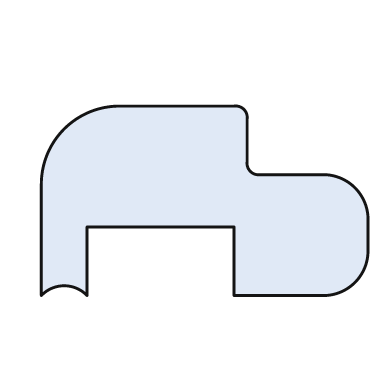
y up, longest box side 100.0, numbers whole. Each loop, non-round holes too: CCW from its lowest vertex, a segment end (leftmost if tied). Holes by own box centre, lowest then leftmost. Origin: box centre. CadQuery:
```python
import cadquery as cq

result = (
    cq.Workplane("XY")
    .moveTo(-50.0, -29.0)
    .threePointArc((-43.0, -26.0), (-36.0, -29.0))
    .lineTo(-36.0, -8.0)
    .lineTo(9.0, -8.0)
    .lineTo(9.0, -29.0)
    .lineTo(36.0, -29.0)
    .threePointArc((46.0, -25.0), (50.0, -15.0))
    .lineTo(50.0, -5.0)
    .threePointArc((46.0, 4.0), (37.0, 8.0))
    .lineTo(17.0, 8.0)
    .threePointArc((14.0, 9.0), (13.0, 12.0))
    .lineTo(13.0, 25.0)
    .threePointArc((12.0, 28.0), (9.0, 29.0))
    .lineTo(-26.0, 29.0)
    .threePointArc((-43.0, 22.0), (-50.0, 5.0))
    .close()
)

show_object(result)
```